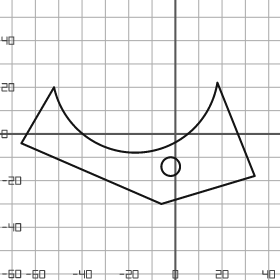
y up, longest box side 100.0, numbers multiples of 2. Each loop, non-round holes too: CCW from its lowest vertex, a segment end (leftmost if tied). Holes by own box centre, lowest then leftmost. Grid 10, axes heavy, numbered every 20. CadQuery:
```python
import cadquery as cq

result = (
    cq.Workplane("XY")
    .moveTo(-6.0, -30.0)
    .lineTo(34.0, -18.0)
    .lineTo(18.0, 22.0)
    .threePointArc((-16.0, -8.0), (-52.0, 20.0))
    .lineTo(-66.0, -4.0)
    .close()
    .moveTo(-2.0, -14.0)
    .circle(4.0)
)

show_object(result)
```